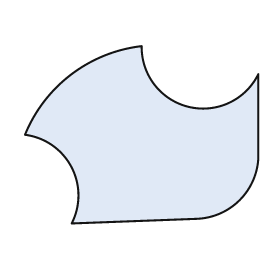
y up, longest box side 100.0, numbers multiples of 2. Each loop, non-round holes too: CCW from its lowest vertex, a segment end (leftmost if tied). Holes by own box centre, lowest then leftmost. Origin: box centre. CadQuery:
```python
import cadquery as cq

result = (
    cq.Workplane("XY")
    .moveTo(-30.0, -38.0)
    .lineTo(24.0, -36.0)
    .threePointArc((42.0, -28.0), (50.0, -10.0))
    .lineTo(50.0, 26.0)
    .threePointArc((20.0, 12.0), (0.0, 38.0))
    .threePointArc((-30.0, 26.0), (-50.0, 0.0))
    .threePointArc((-30.0, -14.0), (-30.0, -38.0))
    .close()
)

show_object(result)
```